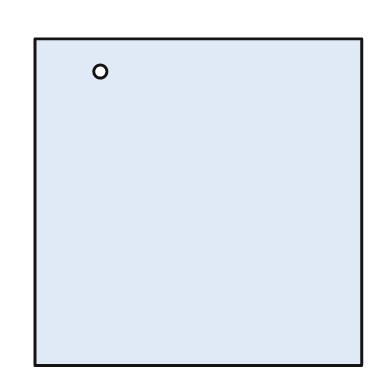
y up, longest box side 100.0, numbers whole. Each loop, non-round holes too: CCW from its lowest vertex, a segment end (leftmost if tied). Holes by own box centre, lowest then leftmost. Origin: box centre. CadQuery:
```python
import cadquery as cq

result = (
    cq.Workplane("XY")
    .moveTo(-50.0, -50.0)
    .lineTo(50.0, -50.0)
    .lineTo(50.0, 50.0)
    .lineTo(-50.0, 50.0)
    .close()
    .moveTo(-30.0, 40.0)
    .circle(2.0)
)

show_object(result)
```